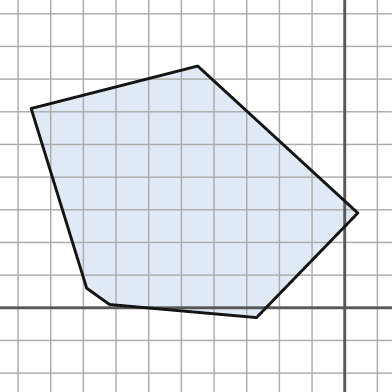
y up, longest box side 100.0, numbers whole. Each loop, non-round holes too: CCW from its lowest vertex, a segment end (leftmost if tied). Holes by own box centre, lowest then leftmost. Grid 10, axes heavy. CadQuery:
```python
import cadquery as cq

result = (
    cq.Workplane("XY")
    .moveTo(-27.0, -3.0)
    .lineTo(4.0, 29.0)
    .lineTo(-45.0, 74.0)
    .lineTo(-96.0, 61.0)
    .lineTo(-79.0, 6.0)
    .lineTo(-72.0, 1.0)
    .close()
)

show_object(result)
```